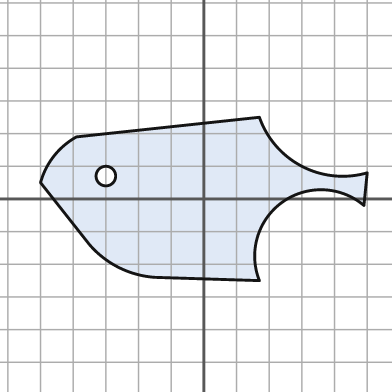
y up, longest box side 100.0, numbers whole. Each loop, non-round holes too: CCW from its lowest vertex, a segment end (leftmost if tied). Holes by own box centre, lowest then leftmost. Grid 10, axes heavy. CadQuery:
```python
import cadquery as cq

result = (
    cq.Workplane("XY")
    .moveTo(17.0, -25.0)
    .threePointArc((24.0, -1.0), (49.0, -2.0))
    .lineTo(50.0, 8.0)
    .threePointArc((30.0, 10.0), (17.0, 25.0))
    .lineTo(-39.0, 19.0)
    .threePointArc((-46.0, 13.0), (-50.0, 5.0))
    .lineTo(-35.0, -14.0)
    .threePointArc((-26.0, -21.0), (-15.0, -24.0))
    .close()
    .moveTo(-30.0, 7.0)
    .circle(3.0)
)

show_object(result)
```